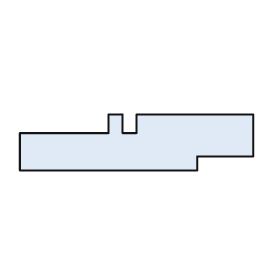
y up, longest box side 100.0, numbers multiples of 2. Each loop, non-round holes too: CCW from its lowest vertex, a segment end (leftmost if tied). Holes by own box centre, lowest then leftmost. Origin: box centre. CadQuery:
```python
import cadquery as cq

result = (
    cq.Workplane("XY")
    .moveTo(-50.0, -12.0)
    .lineTo(26.0, -12.0)
    .lineTo(26.0, -6.0)
    .lineTo(50.0, -6.0)
    .lineTo(50.0, 12.0)
    .lineTo(0.0, 12.0)
    .lineTo(0.0, 4.0)
    .lineTo(-6.0, 4.0)
    .lineTo(-6.0, 12.0)
    .lineTo(-12.0, 12.0)
    .lineTo(-12.0, 4.0)
    .lineTo(-50.0, 4.0)
    .close()
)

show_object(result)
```